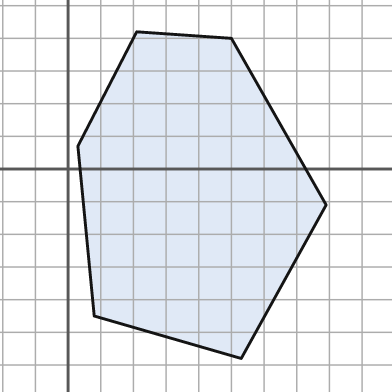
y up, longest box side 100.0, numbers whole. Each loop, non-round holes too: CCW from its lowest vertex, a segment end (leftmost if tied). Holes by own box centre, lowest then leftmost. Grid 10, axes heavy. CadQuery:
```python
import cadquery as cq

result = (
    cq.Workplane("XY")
    .moveTo(53.0, -58.0)
    .lineTo(79.0, -11.0)
    .lineTo(50.0, 40.0)
    .lineTo(21.0, 42.0)
    .lineTo(3.0, 7.0)
    .lineTo(8.0, -45.0)
    .close()
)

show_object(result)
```